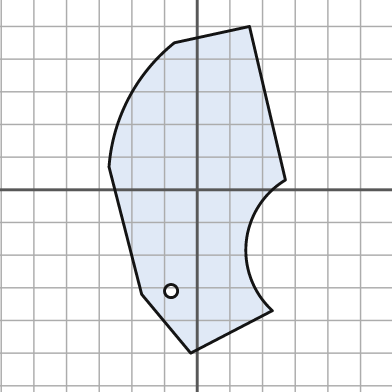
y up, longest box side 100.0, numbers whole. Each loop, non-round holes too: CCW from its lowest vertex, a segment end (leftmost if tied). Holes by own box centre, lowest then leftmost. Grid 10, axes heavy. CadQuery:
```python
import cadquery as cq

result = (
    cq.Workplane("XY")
    .moveTo(-2.0, -50.0)
    .lineTo(23.0, -37.0)
    .threePointArc((15.0, -16.0), (27.0, 3.0))
    .lineTo(16.0, 50.0)
    .lineTo(-7.0, 45.0)
    .threePointArc((-21.0, 28.0), (-27.0, 7.0))
    .lineTo(-17.0, -32.0)
    .close()
    .moveTo(-8.0, -31.0)
    .circle(2.0)
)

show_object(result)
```